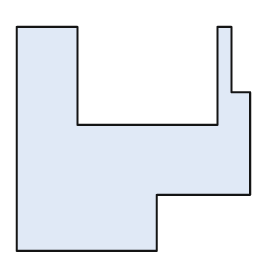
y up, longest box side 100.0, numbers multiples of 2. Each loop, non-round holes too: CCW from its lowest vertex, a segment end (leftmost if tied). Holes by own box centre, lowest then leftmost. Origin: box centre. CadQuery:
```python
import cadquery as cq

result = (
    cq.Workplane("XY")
    .moveTo(-50.0, -48.0)
    .lineTo(10.0, -48.0)
    .lineTo(10.0, -24.0)
    .lineTo(50.0, -24.0)
    .lineTo(50.0, 20.0)
    .lineTo(42.0, 20.0)
    .lineTo(42.0, 48.0)
    .lineTo(36.0, 48.0)
    .lineTo(36.0, 6.0)
    .lineTo(-24.0, 6.0)
    .lineTo(-24.0, 48.0)
    .lineTo(-50.0, 48.0)
    .close()
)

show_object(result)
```